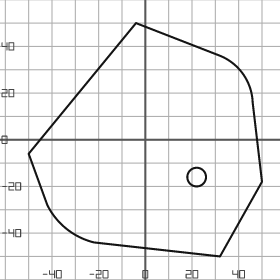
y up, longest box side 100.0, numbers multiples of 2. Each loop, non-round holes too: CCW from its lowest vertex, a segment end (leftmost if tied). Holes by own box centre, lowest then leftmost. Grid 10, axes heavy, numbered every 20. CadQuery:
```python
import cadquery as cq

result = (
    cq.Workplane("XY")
    .moveTo(32.0, -50.0)
    .lineTo(50.0, -18.0)
    .lineTo(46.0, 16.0)
    .threePointArc((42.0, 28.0), (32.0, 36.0))
    .lineTo(-4.0, 50.0)
    .lineTo(-50.0, -6.0)
    .lineTo(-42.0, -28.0)
    .threePointArc((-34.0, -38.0), (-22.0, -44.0))
    .close()
    .moveTo(22.0, -16.0)
    .circle(4.0)
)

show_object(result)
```